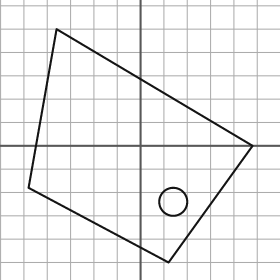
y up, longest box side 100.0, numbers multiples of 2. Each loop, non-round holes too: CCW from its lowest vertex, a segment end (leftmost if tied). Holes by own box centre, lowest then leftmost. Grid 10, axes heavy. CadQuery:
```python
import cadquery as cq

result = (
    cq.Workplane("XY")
    .moveTo(12.0, -50.0)
    .lineTo(48.0, 0.0)
    .lineTo(-36.0, 50.0)
    .lineTo(-48.0, -18.0)
    .close()
    .moveTo(14.0, -24.0)
    .circle(6.0)
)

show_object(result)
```